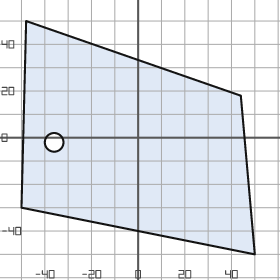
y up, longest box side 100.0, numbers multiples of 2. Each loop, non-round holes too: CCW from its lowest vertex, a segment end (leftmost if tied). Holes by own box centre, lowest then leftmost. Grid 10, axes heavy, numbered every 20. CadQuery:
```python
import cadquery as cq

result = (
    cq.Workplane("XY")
    .moveTo(50.0, -50.0)
    .lineTo(44.0, 18.0)
    .lineTo(-48.0, 50.0)
    .lineTo(-50.0, -30.0)
    .close()
    .moveTo(-36.0, -2.0)
    .circle(4.0)
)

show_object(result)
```